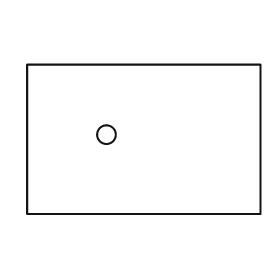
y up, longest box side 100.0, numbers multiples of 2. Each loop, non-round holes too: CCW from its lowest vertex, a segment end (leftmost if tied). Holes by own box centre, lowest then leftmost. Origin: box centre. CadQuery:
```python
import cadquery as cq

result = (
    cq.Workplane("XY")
    .moveTo(-50.0, -32.0)
    .lineTo(50.0, -32.0)
    .lineTo(50.0, 32.0)
    .lineTo(-50.0, 32.0)
    .close()
    .moveTo(-16.0, 2.0)
    .circle(4.0)
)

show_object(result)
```